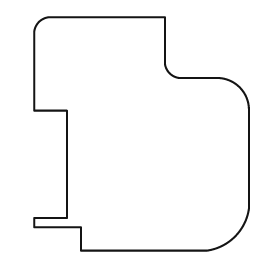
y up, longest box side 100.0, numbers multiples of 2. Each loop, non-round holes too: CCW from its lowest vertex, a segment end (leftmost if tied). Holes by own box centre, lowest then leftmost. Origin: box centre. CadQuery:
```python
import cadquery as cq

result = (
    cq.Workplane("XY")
    .moveTo(-26.0, -50.0)
    .lineTo(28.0, -50.0)
    .threePointArc((40.0, -44.0), (46.0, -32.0))
    .lineTo(46.0, 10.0)
    .threePointArc((42.0, 20.0), (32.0, 24.0))
    .lineTo(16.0, 24.0)
    .threePointArc((12.0, 26.0), (10.0, 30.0))
    .lineTo(10.0, 50.0)
    .lineTo(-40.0, 50.0)
    .threePointArc((-44.0, 48.0), (-46.0, 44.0))
    .lineTo(-46.0, 10.0)
    .lineTo(-32.0, 10.0)
    .lineTo(-32.0, -36.0)
    .lineTo(-46.0, -36.0)
    .lineTo(-46.0, -40.0)
    .lineTo(-26.0, -40.0)
    .close()
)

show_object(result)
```